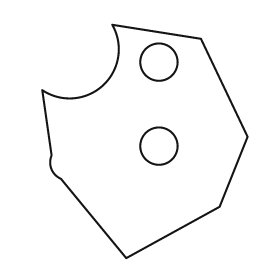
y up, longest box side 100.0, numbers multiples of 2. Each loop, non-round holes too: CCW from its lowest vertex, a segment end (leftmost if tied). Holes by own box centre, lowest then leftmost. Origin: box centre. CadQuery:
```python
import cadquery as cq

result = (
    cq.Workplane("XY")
    .moveTo(-8.0, -50.0)
    .lineTo(32.0, -28.0)
    .lineTo(44.0, 2.0)
    .lineTo(24.0, 44.0)
    .lineTo(-14.0, 50.0)
    .threePointArc((-18.0, 24.0), (-44.0, 22.0))
    .lineTo(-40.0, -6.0)
    .threePointArc((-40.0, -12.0), (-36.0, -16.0))
    .close()
    .moveTo(6.0, -2.0)
    .circle(8.0)
    .moveTo(6.0, 34.0)
    .circle(8.0)
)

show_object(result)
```